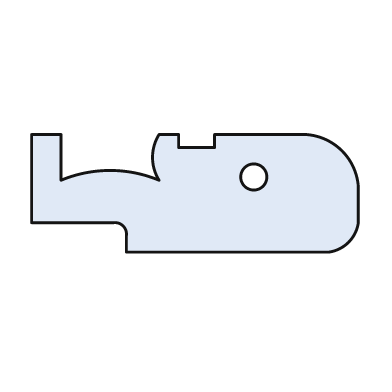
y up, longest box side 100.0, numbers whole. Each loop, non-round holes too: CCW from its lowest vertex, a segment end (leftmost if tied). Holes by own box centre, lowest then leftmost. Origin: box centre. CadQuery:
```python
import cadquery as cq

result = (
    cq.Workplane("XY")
    .moveTo(-21.0, -18.0)
    .lineTo(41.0, -18.0)
    .threePointArc((47.0, -15.0), (50.0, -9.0))
    .lineTo(50.0, 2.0)
    .threePointArc((45.0, 13.0), (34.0, 18.0))
    .lineTo(6.0, 18.0)
    .lineTo(6.0, 14.0)
    .lineTo(-5.0, 14.0)
    .lineTo(-5.0, 18.0)
    .lineTo(-11.0, 18.0)
    .threePointArc((-13.0, 11.0), (-11.0, 4.0))
    .threePointArc((-26.0, 7.0), (-41.0, 4.0))
    .lineTo(-41.0, 18.0)
    .lineTo(-50.0, 18.0)
    .lineTo(-50.0, -9.0)
    .lineTo(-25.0, -9.0)
    .threePointArc((-22.0, -10.0), (-21.0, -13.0))
    .close()
    .moveTo(18.0, 5.0)
    .circle(4.0)
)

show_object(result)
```